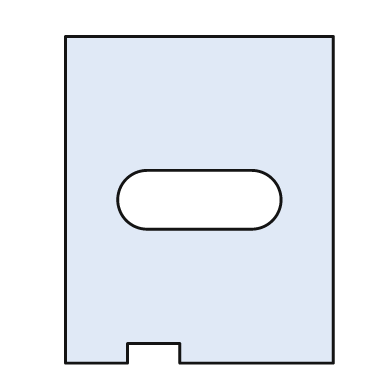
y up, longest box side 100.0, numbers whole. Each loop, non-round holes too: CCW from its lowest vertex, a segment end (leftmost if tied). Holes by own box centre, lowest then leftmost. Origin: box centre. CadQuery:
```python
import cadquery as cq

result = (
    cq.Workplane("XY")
    .moveTo(-41.0, -50.0)
    .lineTo(-22.0, -50.0)
    .lineTo(-22.0, -44.0)
    .lineTo(-6.0, -44.0)
    .lineTo(-6.0, -50.0)
    .lineTo(41.0, -50.0)
    .lineTo(41.0, 50.0)
    .lineTo(-41.0, 50.0)
    .close()
    .moveTo(-16.0, -9.0)
    .lineTo(16.0, -9.0)
    .threePointArc((25.0, 0.0), (16.0, 9.0))
    .lineTo(-16.0, 9.0)
    .threePointArc((-25.0, 0.0), (-16.0, -9.0))
    .close()
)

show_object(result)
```